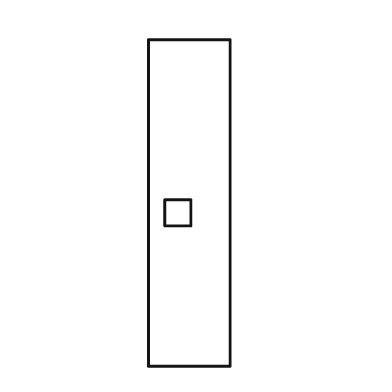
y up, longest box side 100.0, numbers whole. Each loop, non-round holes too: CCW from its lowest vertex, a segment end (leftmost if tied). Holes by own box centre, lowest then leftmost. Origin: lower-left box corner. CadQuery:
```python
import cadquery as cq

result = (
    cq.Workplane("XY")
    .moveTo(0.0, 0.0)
    .lineTo(25.0, 0.0)
    .lineTo(25.0, 100.0)
    .lineTo(0.0, 100.0)
    .close()
    .moveTo(5.0, 43.0)
    .lineTo(13.0, 43.0)
    .lineTo(13.0, 51.0)
    .lineTo(5.0, 51.0)
    .close()
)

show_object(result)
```